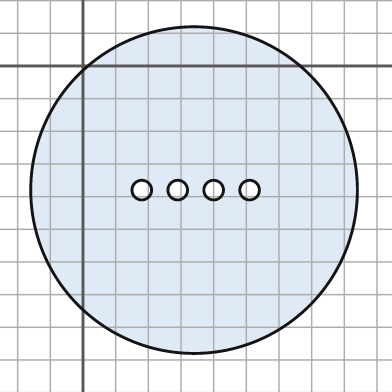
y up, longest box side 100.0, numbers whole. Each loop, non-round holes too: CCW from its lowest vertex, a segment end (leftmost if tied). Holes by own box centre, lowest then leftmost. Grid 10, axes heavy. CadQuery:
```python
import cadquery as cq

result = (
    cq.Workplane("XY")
    .moveTo(34.0, -38.0)
    .circle(50.0)
    .moveTo(18.0, -38.0)
    .circle(3.0)
    .moveTo(29.0, -38.0)
    .circle(3.0)
    .moveTo(40.0, -38.0)
    .circle(3.0)
    .moveTo(51.0, -38.0)
    .circle(3.0)
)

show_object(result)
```